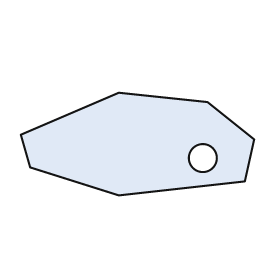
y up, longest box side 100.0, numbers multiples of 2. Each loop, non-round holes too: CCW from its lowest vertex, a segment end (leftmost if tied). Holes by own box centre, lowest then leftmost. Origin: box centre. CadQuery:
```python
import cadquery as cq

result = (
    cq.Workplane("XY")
    .moveTo(-8.0, -22.0)
    .lineTo(46.0, -16.0)
    .lineTo(50.0, 2.0)
    .lineTo(30.0, 18.0)
    .lineTo(-8.0, 22.0)
    .lineTo(-50.0, 4.0)
    .lineTo(-46.0, -10.0)
    .close()
    .moveTo(28.0, -6.0)
    .circle(6.0)
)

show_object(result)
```